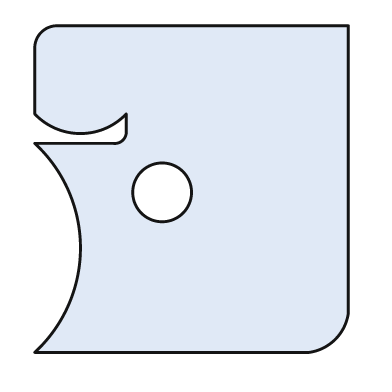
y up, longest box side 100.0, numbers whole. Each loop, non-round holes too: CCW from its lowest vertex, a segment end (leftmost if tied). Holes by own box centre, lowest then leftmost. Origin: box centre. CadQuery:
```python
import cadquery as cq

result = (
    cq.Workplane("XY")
    .moveTo(-48.0, -50.0)
    .lineTo(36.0, -50.0)
    .threePointArc((44.0, -46.0), (48.0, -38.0))
    .lineTo(48.0, 50.0)
    .lineTo(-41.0, 50.0)
    .threePointArc((-46.0, 48.0), (-48.0, 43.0))
    .lineTo(-48.0, 23.0)
    .threePointArc((-34.0, 17.0), (-20.0, 23.0))
    .lineTo(-20.0, 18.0)
    .threePointArc((-21.0, 15.0), (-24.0, 14.0))
    .lineTo(-48.0, 14.0)
    .threePointArc((-34.0, -18.0), (-48.0, -50.0))
    .close()
    .moveTo(-9.0, -1.0)
    .circle(9.0)
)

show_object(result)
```